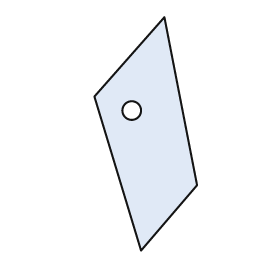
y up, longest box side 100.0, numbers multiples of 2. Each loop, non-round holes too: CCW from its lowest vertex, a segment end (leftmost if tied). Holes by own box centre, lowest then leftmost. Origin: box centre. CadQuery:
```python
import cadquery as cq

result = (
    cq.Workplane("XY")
    .moveTo(-2.0, -50.0)
    .lineTo(22.0, -22.0)
    .lineTo(8.0, 50.0)
    .lineTo(-22.0, 16.0)
    .close()
    .moveTo(-6.0, 10.0)
    .circle(4.0)
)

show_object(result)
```